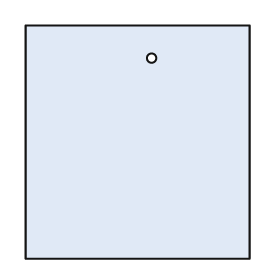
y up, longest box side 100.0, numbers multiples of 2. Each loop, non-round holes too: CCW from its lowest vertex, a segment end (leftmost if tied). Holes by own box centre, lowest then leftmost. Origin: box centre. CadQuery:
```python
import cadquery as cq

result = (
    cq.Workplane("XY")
    .moveTo(-48.0, -50.0)
    .lineTo(48.0, -50.0)
    .lineTo(48.0, 50.0)
    .lineTo(-48.0, 50.0)
    .close()
    .moveTo(6.0, 36.0)
    .circle(2.0)
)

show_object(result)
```